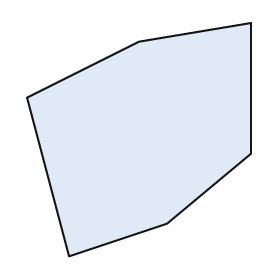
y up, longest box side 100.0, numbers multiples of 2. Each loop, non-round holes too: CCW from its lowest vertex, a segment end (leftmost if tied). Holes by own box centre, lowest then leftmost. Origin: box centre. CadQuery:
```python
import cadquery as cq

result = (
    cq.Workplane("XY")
    .moveTo(-30.0, -50.0)
    .lineTo(12.0, -36.0)
    .lineTo(48.0, -6.0)
    .lineTo(48.0, 50.0)
    .lineTo(0.0, 42.0)
    .lineTo(-48.0, 18.0)
    .close()
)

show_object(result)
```